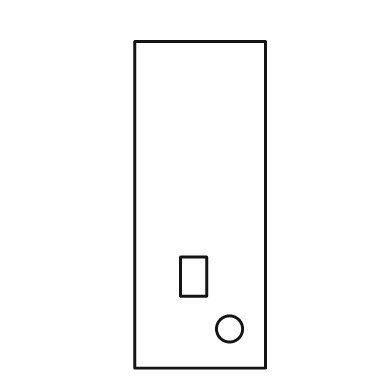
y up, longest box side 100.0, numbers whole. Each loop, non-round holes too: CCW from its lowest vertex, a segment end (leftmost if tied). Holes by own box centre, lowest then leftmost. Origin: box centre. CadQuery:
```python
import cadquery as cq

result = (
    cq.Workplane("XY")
    .moveTo(-20.0, -50.0)
    .lineTo(20.0, -50.0)
    .lineTo(20.0, 50.0)
    .lineTo(-20.0, 50.0)
    .close()
    .moveTo(9.0, -38.0)
    .circle(4.0)
    .moveTo(-6.0, -28.0)
    .lineTo(2.0, -28.0)
    .lineTo(2.0, -16.0)
    .lineTo(-6.0, -16.0)
    .close()
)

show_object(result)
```